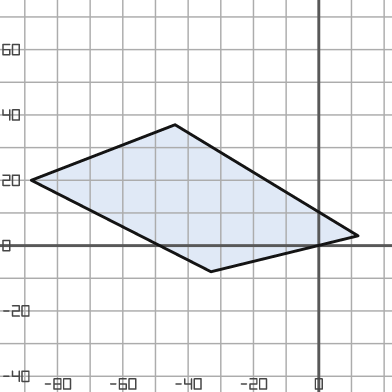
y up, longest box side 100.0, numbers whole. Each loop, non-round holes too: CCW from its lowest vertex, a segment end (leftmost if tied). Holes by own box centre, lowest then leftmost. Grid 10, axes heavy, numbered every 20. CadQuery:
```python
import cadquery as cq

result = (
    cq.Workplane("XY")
    .moveTo(-33.0, -8.0)
    .lineTo(12.0, 3.0)
    .lineTo(-44.0, 37.0)
    .lineTo(-88.0, 20.0)
    .close()
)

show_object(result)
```